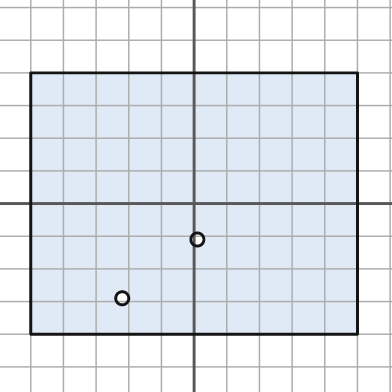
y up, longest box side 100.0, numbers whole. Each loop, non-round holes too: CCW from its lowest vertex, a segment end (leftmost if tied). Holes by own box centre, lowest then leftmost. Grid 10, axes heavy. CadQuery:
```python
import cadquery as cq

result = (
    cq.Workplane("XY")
    .moveTo(-50.0, -40.0)
    .lineTo(50.0, -40.0)
    .lineTo(50.0, 40.0)
    .lineTo(-50.0, 40.0)
    .close()
    .moveTo(-22.0, -29.0)
    .circle(2.0)
    .moveTo(1.0, -11.0)
    .circle(2.0)
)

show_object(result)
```